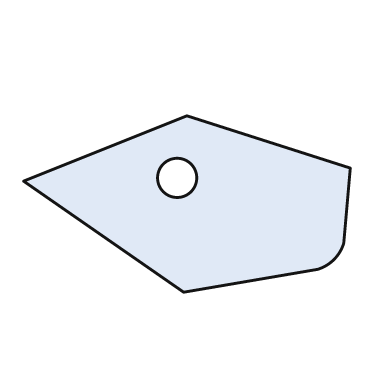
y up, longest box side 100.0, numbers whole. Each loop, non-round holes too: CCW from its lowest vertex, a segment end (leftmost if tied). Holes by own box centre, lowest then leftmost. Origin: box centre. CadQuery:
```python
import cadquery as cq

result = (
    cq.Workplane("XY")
    .moveTo(-1.0, -27.0)
    .lineTo(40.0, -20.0)
    .threePointArc((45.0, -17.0), (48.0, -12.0))
    .lineTo(50.0, 11.0)
    .lineTo(0.0, 27.0)
    .lineTo(-50.0, 7.0)
    .close()
    .moveTo(-3.0, 8.0)
    .circle(6.0)
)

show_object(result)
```